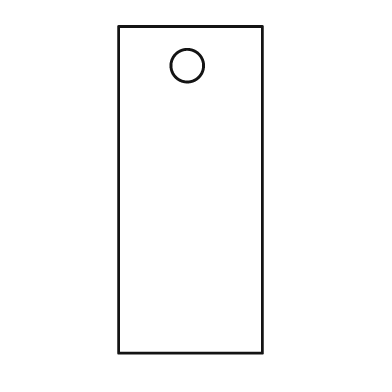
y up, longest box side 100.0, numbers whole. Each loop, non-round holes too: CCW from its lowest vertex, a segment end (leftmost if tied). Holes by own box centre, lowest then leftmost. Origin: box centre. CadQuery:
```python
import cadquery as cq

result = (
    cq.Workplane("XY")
    .moveTo(-22.0, -50.0)
    .lineTo(22.0, -50.0)
    .lineTo(22.0, 50.0)
    .lineTo(-22.0, 50.0)
    .close()
    .moveTo(-1.0, 38.0)
    .circle(5.0)
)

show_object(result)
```